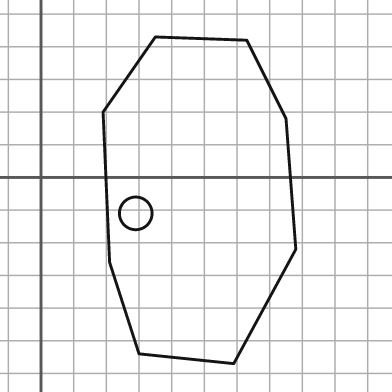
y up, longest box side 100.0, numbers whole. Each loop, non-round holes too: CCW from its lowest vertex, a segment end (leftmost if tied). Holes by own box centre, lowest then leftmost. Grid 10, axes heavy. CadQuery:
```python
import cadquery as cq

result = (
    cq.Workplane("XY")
    .moveTo(59.0, -57.0)
    .lineTo(78.0, -22.0)
    .lineTo(75.0, 18.0)
    .lineTo(63.0, 42.0)
    .lineTo(35.0, 43.0)
    .lineTo(19.0, 20.0)
    .lineTo(21.0, -26.0)
    .lineTo(30.0, -54.0)
    .close()
    .moveTo(29.0, -11.0)
    .circle(5.0)
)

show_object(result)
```